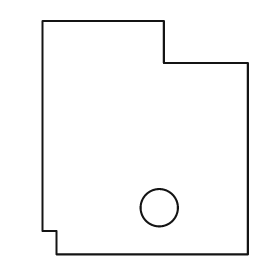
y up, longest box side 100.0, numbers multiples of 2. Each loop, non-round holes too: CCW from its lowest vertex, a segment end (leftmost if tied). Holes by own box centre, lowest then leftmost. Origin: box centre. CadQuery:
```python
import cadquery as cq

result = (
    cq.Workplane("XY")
    .moveTo(-38.0, -50.0)
    .lineTo(44.0, -50.0)
    .lineTo(44.0, 32.0)
    .lineTo(8.0, 32.0)
    .lineTo(8.0, 50.0)
    .lineTo(-44.0, 50.0)
    .lineTo(-44.0, -40.0)
    .lineTo(-38.0, -40.0)
    .close()
    .moveTo(6.0, -30.0)
    .circle(8.0)
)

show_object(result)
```